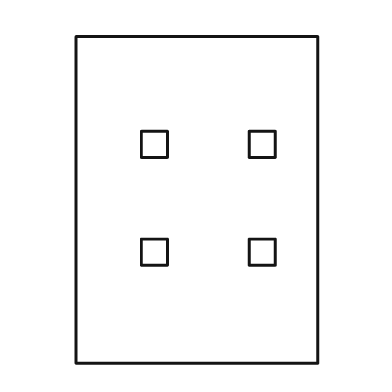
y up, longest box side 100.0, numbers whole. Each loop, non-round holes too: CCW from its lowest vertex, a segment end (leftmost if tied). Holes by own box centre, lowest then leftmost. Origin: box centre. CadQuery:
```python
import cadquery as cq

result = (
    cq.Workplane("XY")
    .moveTo(-37.0, -50.0)
    .lineTo(37.0, -50.0)
    .lineTo(37.0, 50.0)
    .lineTo(-37.0, 50.0)
    .close()
    .moveTo(-17.0, -20.0)
    .lineTo(-9.0, -20.0)
    .lineTo(-9.0, -12.0)
    .lineTo(-17.0, -12.0)
    .close()
    .moveTo(16.0, -20.0)
    .lineTo(24.0, -20.0)
    .lineTo(24.0, -12.0)
    .lineTo(16.0, -12.0)
    .close()
    .moveTo(-17.0, 13.0)
    .lineTo(-9.0, 13.0)
    .lineTo(-9.0, 21.0)
    .lineTo(-17.0, 21.0)
    .close()
    .moveTo(16.0, 13.0)
    .lineTo(24.0, 13.0)
    .lineTo(24.0, 21.0)
    .lineTo(16.0, 21.0)
    .close()
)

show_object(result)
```